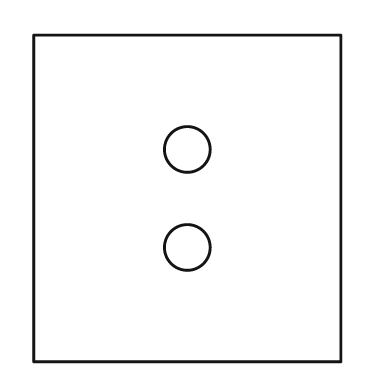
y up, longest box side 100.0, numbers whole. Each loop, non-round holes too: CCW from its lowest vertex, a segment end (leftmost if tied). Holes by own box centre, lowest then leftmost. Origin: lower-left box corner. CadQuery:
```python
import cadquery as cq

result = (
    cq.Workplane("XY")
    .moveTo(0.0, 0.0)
    .lineTo(94.0, 0.0)
    .lineTo(94.0, 100.0)
    .lineTo(0.0, 100.0)
    .close()
    .moveTo(47.0, 35.0)
    .circle(7.0)
    .moveTo(47.0, 65.0)
    .circle(7.0)
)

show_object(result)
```